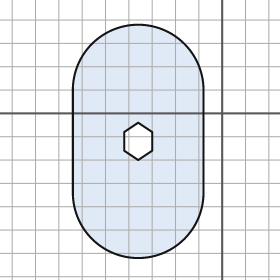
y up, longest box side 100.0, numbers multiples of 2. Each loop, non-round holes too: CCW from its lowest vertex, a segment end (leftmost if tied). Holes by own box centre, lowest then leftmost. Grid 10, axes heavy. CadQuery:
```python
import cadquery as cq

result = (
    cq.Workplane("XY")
    .moveTo(-64.0, -34.0)
    .threePointArc((-36.0, -62.0), (-8.0, -34.0))
    .lineTo(-8.0, 10.0)
    .threePointArc((-36.0, 38.0), (-64.0, 10.0))
    .close()
    .moveTo(-36.0, -20.0)
    .lineTo(-30.0, -16.0)
    .lineTo(-30.0, -8.0)
    .lineTo(-36.0, -4.0)
    .lineTo(-42.0, -8.0)
    .lineTo(-42.0, -16.0)
    .close()
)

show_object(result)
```